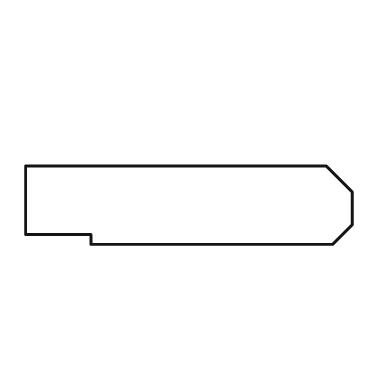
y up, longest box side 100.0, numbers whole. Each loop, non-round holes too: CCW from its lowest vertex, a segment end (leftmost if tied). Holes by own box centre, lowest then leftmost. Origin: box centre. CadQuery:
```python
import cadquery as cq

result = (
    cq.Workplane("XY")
    .moveTo(-30.0, -12.0)
    .lineTo(44.0, -12.0)
    .lineTo(50.0, -6.0)
    .lineTo(50.0, 4.0)
    .lineTo(42.0, 12.0)
    .lineTo(-50.0, 12.0)
    .lineTo(-50.0, -9.0)
    .lineTo(-30.0, -9.0)
    .close()
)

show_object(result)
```